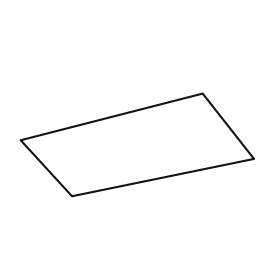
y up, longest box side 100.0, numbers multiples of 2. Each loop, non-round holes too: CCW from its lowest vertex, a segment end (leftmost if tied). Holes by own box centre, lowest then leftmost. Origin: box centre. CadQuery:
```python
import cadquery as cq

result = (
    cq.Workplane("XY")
    .moveTo(-28.0, -22.0)
    .lineTo(50.0, -6.0)
    .lineTo(28.0, 22.0)
    .lineTo(-50.0, 2.0)
    .close()
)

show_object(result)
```